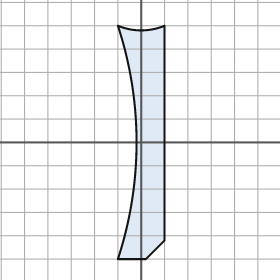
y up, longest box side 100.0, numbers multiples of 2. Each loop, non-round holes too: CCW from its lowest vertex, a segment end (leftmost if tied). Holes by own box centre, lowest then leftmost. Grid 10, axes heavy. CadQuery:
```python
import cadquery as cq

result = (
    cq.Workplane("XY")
    .moveTo(-10.0, -50.0)
    .lineTo(2.0, -50.0)
    .lineTo(10.0, -42.0)
    .lineTo(10.0, 50.0)
    .threePointArc((0.0, 48.0), (-10.0, 50.0))
    .threePointArc((-2.0, 0.0), (-10.0, -50.0))
    .close()
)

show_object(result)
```